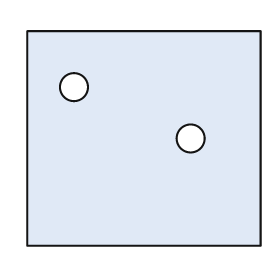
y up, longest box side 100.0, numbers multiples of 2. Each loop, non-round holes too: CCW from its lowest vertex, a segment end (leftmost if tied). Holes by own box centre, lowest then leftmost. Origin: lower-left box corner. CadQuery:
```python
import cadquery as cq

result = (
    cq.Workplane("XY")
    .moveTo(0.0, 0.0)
    .lineTo(100.0, 0.0)
    .lineTo(100.0, 92.0)
    .lineTo(0.0, 92.0)
    .close()
    .moveTo(70.0, 46.0)
    .circle(6.0)
    .moveTo(20.0, 68.0)
    .circle(6.0)
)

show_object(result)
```